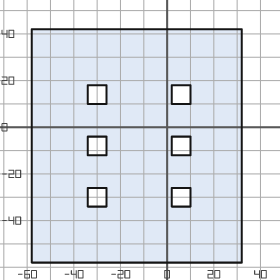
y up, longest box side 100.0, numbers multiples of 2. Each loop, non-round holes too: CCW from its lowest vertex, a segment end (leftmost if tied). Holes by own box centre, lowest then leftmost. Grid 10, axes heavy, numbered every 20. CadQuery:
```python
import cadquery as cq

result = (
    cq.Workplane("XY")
    .moveTo(-58.0, -58.0)
    .lineTo(32.0, -58.0)
    .lineTo(32.0, 42.0)
    .lineTo(-58.0, 42.0)
    .close()
    .moveTo(-34.0, -34.0)
    .lineTo(-26.0, -34.0)
    .lineTo(-26.0, -26.0)
    .lineTo(-34.0, -26.0)
    .close()
    .moveTo(2.0, -34.0)
    .lineTo(10.0, -34.0)
    .lineTo(10.0, -26.0)
    .lineTo(2.0, -26.0)
    .close()
    .moveTo(-34.0, -12.0)
    .lineTo(-26.0, -12.0)
    .lineTo(-26.0, -4.0)
    .lineTo(-34.0, -4.0)
    .close()
    .moveTo(2.0, -12.0)
    .lineTo(10.0, -12.0)
    .lineTo(10.0, -4.0)
    .lineTo(2.0, -4.0)
    .close()
    .moveTo(-34.0, 10.0)
    .lineTo(-26.0, 10.0)
    .lineTo(-26.0, 18.0)
    .lineTo(-34.0, 18.0)
    .close()
    .moveTo(2.0, 10.0)
    .lineTo(10.0, 10.0)
    .lineTo(10.0, 18.0)
    .lineTo(2.0, 18.0)
    .close()
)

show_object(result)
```